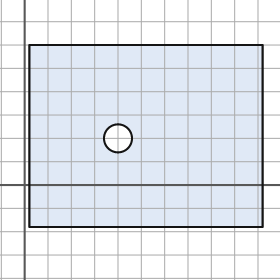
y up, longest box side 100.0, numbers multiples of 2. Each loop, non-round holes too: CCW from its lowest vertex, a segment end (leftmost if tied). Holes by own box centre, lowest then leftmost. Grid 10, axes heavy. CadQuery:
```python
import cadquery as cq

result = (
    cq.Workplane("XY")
    .moveTo(2.0, -18.0)
    .lineTo(102.0, -18.0)
    .lineTo(102.0, 60.0)
    .lineTo(2.0, 60.0)
    .close()
    .moveTo(40.0, 20.0)
    .circle(6.0)
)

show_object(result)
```